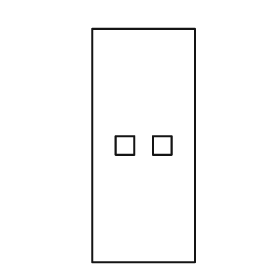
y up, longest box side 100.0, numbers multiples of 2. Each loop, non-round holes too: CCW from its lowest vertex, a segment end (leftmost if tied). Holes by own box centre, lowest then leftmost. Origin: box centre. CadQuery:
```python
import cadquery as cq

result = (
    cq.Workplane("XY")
    .moveTo(-22.0, -50.0)
    .lineTo(22.0, -50.0)
    .lineTo(22.0, 50.0)
    .lineTo(-22.0, 50.0)
    .close()
    .moveTo(-12.0, -4.0)
    .lineTo(-4.0, -4.0)
    .lineTo(-4.0, 4.0)
    .lineTo(-12.0, 4.0)
    .close()
    .moveTo(4.0, -4.0)
    .lineTo(12.0, -4.0)
    .lineTo(12.0, 4.0)
    .lineTo(4.0, 4.0)
    .close()
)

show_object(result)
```